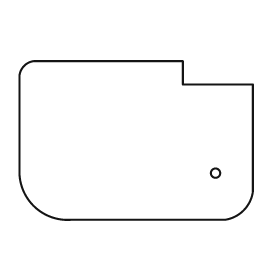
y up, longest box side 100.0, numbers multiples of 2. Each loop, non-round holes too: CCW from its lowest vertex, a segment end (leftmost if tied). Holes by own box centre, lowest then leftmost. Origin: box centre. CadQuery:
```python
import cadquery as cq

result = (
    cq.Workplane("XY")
    .moveTo(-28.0, -34.0)
    .lineTo(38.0, -34.0)
    .threePointArc((46.0, -30.0), (50.0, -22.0))
    .lineTo(50.0, 24.0)
    .lineTo(20.0, 24.0)
    .lineTo(20.0, 34.0)
    .lineTo(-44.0, 34.0)
    .threePointArc((-48.0, 32.0), (-50.0, 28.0))
    .lineTo(-50.0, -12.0)
    .threePointArc((-44.0, -28.0), (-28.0, -34.0))
    .close()
    .moveTo(34.0, -14.0)
    .circle(2.0)
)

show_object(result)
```